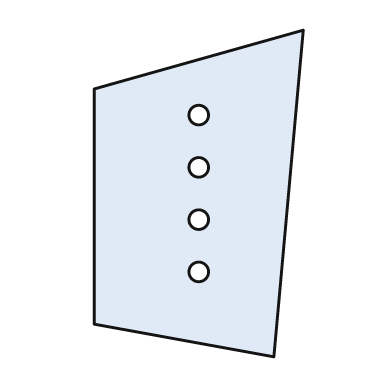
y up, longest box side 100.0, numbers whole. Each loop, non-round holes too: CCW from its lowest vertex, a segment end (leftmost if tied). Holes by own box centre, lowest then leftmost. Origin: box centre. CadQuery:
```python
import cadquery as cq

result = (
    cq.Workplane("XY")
    .moveTo(23.0, -50.0)
    .lineTo(32.0, 50.0)
    .lineTo(-32.0, 32.0)
    .lineTo(-32.0, -40.0)
    .close()
    .moveTo(0.0, -24.0)
    .circle(3.0)
    .moveTo(0.0, -8.0)
    .circle(3.0)
    .moveTo(0.0, 8.0)
    .circle(3.0)
    .moveTo(0.0, 24.0)
    .circle(3.0)
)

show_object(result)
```